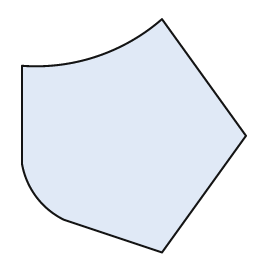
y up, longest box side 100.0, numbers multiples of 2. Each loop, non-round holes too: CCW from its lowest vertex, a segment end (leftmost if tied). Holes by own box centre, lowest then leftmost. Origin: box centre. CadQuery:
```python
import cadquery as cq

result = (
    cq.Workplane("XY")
    .moveTo(12.0, -50.0)
    .lineTo(48.0, 0.0)
    .lineTo(12.0, 50.0)
    .threePointArc((-16.0, 34.0), (-48.0, 30.0))
    .lineTo(-48.0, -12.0)
    .threePointArc((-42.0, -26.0), (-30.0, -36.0))
    .close()
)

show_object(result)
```